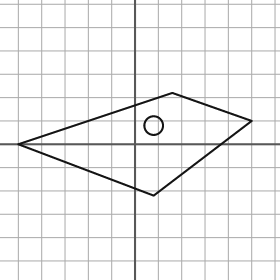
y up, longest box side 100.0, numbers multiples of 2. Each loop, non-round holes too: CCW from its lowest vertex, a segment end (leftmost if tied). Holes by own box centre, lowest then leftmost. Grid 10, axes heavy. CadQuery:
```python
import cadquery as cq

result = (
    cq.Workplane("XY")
    .moveTo(8.0, -22.0)
    .lineTo(50.0, 10.0)
    .lineTo(16.0, 22.0)
    .lineTo(-50.0, 0.0)
    .close()
    .moveTo(8.0, 8.0)
    .circle(4.0)
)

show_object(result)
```